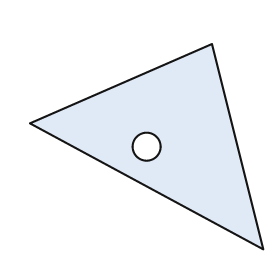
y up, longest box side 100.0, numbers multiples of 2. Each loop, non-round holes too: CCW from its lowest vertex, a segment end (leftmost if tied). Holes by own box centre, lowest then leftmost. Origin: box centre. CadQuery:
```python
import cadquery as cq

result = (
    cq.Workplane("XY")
    .moveTo(50.0, -44.0)
    .lineTo(28.0, 44.0)
    .lineTo(-50.0, 10.0)
    .close()
    .moveTo(0.0, 0.0)
    .circle(6.0)
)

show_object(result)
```